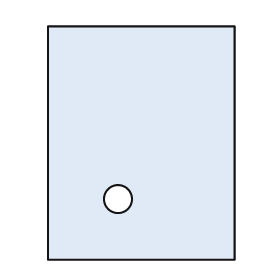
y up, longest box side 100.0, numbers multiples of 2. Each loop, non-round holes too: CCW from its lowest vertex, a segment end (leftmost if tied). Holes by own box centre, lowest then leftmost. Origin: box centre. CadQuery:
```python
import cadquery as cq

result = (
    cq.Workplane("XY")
    .moveTo(-40.0, -50.0)
    .lineTo(40.0, -50.0)
    .lineTo(40.0, 50.0)
    .lineTo(-40.0, 50.0)
    .close()
    .moveTo(-10.0, -24.0)
    .circle(6.0)
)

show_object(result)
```